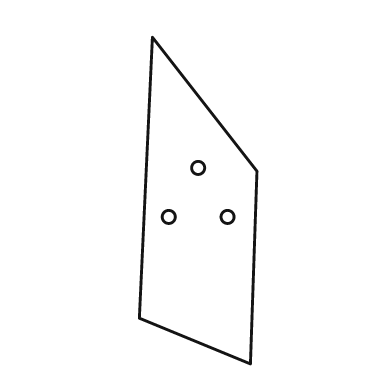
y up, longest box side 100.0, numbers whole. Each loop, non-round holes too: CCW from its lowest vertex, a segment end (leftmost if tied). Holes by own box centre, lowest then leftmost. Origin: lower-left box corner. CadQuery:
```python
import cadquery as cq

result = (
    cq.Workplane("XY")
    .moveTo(34.0, 0.0)
    .lineTo(36.0, 59.0)
    .lineTo(4.0, 100.0)
    .lineTo(0.0, 14.0)
    .close()
    .moveTo(9.0, 45.0)
    .circle(2.0)
    .moveTo(27.0, 45.0)
    .circle(2.0)
    .moveTo(18.0, 60.0)
    .circle(2.0)
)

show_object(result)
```